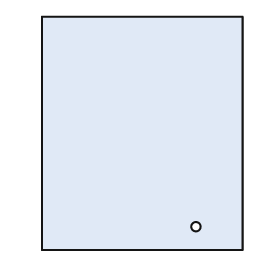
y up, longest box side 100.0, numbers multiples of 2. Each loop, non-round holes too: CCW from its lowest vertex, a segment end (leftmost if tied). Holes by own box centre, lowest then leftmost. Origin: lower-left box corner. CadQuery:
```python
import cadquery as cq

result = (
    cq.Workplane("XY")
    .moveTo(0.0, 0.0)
    .lineTo(86.0, 0.0)
    .lineTo(86.0, 100.0)
    .lineTo(0.0, 100.0)
    .close()
    .moveTo(66.0, 10.0)
    .circle(2.0)
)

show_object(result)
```